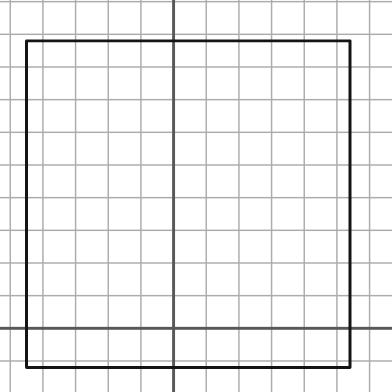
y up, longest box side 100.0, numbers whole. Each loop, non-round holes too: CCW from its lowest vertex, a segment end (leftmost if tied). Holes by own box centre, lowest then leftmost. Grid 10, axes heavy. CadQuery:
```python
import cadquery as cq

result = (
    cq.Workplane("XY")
    .moveTo(-45.0, -12.0)
    .lineTo(54.0, -12.0)
    .lineTo(54.0, 88.0)
    .lineTo(-45.0, 88.0)
    .close()
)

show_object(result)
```